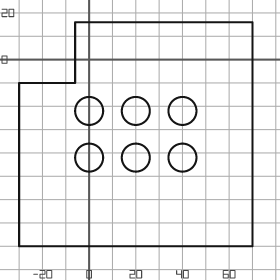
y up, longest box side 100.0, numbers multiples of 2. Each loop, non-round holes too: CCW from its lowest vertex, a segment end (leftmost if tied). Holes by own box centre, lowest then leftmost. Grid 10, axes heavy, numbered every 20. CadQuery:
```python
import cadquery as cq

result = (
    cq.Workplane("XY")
    .moveTo(-30.0, -80.0)
    .lineTo(70.0, -80.0)
    .lineTo(70.0, 16.0)
    .lineTo(-6.0, 16.0)
    .lineTo(-6.0, -10.0)
    .lineTo(-30.0, -10.0)
    .close()
    .moveTo(0.0, -42.0)
    .circle(6.0)
    .moveTo(20.0, -42.0)
    .circle(6.0)
    .moveTo(40.0, -42.0)
    .circle(6.0)
    .moveTo(0.0, -22.0)
    .circle(6.0)
    .moveTo(20.0, -22.0)
    .circle(6.0)
    .moveTo(40.0, -22.0)
    .circle(6.0)
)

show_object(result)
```